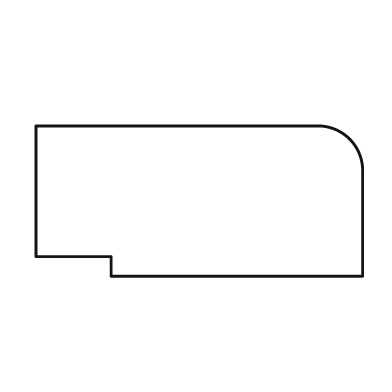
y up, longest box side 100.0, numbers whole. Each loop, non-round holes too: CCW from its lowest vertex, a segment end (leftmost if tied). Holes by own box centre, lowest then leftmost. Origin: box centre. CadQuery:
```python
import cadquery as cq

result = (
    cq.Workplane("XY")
    .moveTo(-27.0, -23.0)
    .lineTo(50.0, -23.0)
    .lineTo(50.0, 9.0)
    .threePointArc((46.0, 19.0), (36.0, 23.0))
    .lineTo(-50.0, 23.0)
    .lineTo(-50.0, -17.0)
    .lineTo(-27.0, -17.0)
    .close()
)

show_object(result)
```